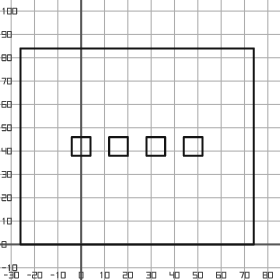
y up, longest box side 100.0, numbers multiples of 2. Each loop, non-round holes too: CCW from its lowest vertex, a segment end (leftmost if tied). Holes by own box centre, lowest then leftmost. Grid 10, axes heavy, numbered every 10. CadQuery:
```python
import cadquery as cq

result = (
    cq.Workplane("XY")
    .moveTo(-26.0, 0.0)
    .lineTo(74.0, 0.0)
    .lineTo(74.0, 84.0)
    .lineTo(-26.0, 84.0)
    .close()
    .moveTo(-4.0, 38.0)
    .lineTo(4.0, 38.0)
    .lineTo(4.0, 46.0)
    .lineTo(-4.0, 46.0)
    .close()
    .moveTo(12.0, 38.0)
    .lineTo(20.0, 38.0)
    .lineTo(20.0, 46.0)
    .lineTo(12.0, 46.0)
    .close()
    .moveTo(28.0, 38.0)
    .lineTo(36.0, 38.0)
    .lineTo(36.0, 46.0)
    .lineTo(28.0, 46.0)
    .close()
    .moveTo(44.0, 38.0)
    .lineTo(52.0, 38.0)
    .lineTo(52.0, 46.0)
    .lineTo(44.0, 46.0)
    .close()
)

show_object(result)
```